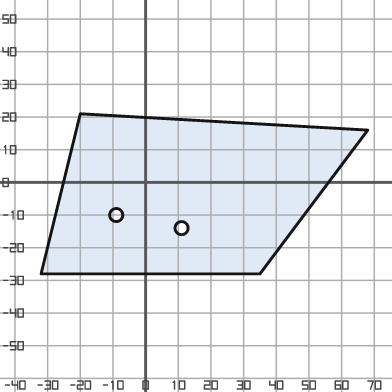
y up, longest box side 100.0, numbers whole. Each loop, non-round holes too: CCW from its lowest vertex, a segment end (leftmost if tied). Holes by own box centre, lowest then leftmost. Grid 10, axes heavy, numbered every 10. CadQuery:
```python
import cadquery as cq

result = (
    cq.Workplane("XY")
    .moveTo(-32.0, -28.0)
    .lineTo(35.0, -28.0)
    .lineTo(68.0, 16.0)
    .lineTo(-20.0, 21.0)
    .close()
    .moveTo(11.0, -14.0)
    .circle(2.0)
    .moveTo(-9.0, -10.0)
    .circle(2.0)
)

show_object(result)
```